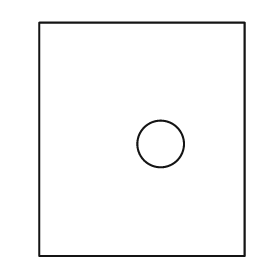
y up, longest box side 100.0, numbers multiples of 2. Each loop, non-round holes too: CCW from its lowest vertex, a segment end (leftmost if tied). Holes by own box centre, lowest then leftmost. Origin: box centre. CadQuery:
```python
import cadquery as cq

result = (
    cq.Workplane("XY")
    .moveTo(-44.0, -50.0)
    .lineTo(44.0, -50.0)
    .lineTo(44.0, 50.0)
    .lineTo(-44.0, 50.0)
    .close()
    .moveTo(8.0, -2.0)
    .circle(10.0)
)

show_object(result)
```